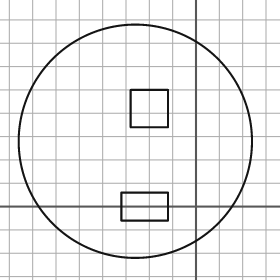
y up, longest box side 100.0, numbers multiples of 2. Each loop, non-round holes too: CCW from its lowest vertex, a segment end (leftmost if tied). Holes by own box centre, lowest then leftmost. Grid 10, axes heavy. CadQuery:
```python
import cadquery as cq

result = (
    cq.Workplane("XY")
    .moveTo(-26.0, 28.0)
    .circle(50.0)
    .moveTo(-32.0, -6.0)
    .lineTo(-12.0, -6.0)
    .lineTo(-12.0, 6.0)
    .lineTo(-32.0, 6.0)
    .close()
    .moveTo(-28.0, 34.0)
    .lineTo(-12.0, 34.0)
    .lineTo(-12.0, 50.0)
    .lineTo(-28.0, 50.0)
    .close()
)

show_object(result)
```